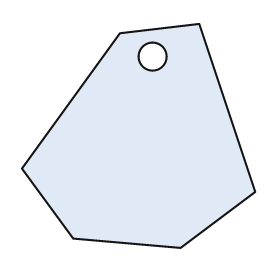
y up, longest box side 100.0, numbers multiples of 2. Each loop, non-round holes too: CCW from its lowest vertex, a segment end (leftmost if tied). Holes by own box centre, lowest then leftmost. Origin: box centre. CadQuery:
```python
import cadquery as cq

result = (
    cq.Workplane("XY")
    .moveTo(18.0, -48.0)
    .lineTo(50.0, -24.0)
    .lineTo(26.0, 48.0)
    .lineTo(-8.0, 44.0)
    .lineTo(-50.0, -14.0)
    .lineTo(-28.0, -44.0)
    .close()
    .moveTo(6.0, 34.0)
    .circle(6.0)
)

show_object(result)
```